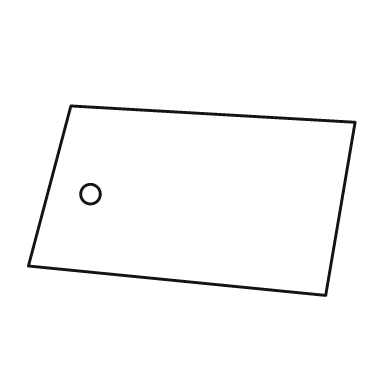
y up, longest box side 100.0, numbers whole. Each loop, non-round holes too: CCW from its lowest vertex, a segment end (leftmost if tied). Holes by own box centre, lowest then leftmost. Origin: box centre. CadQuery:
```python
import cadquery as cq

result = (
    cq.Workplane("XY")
    .moveTo(41.0, -29.0)
    .lineTo(50.0, 24.0)
    .lineTo(-37.0, 29.0)
    .lineTo(-50.0, -20.0)
    .close()
    .moveTo(-31.0, 2.0)
    .circle(3.0)
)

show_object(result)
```